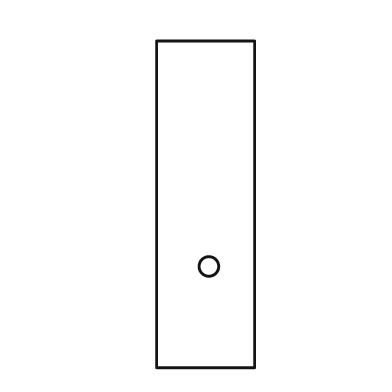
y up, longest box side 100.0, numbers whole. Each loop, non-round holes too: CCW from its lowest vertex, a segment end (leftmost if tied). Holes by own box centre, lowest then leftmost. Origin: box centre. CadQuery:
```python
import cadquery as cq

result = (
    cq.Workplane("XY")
    .moveTo(-15.0, -50.0)
    .lineTo(15.0, -50.0)
    .lineTo(15.0, 50.0)
    .lineTo(-15.0, 50.0)
    .close()
    .moveTo(1.0, -19.0)
    .circle(3.0)
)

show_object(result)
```